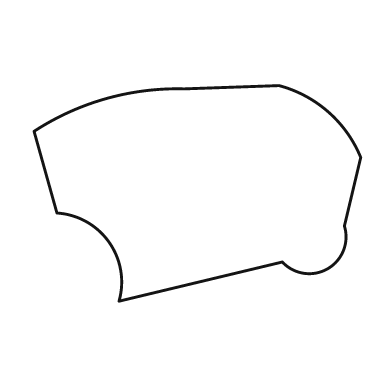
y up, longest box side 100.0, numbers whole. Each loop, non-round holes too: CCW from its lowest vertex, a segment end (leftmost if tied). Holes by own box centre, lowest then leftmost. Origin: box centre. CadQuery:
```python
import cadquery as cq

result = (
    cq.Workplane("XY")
    .moveTo(-24.0, -33.0)
    .lineTo(26.0, -21.0)
    .threePointArc((40.0, -23.0), (45.0, -10.0))
    .lineTo(50.0, 11.0)
    .threePointArc((40.0, 25.0), (25.0, 33.0))
    .lineTo(-4.0, 32.0)
    .threePointArc((-28.0, 29.0), (-50.0, 19.0))
    .lineTo(-43.0, -6.0)
    .threePointArc((-27.0, -15.0), (-24.0, -33.0))
    .close()
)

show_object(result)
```